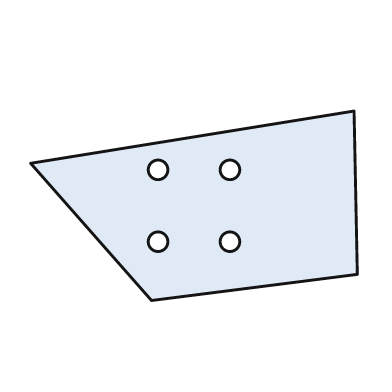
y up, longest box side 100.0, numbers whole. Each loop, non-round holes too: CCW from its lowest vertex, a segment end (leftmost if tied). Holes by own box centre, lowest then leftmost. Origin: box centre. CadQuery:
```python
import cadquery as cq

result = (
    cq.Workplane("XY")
    .moveTo(-13.0, -29.0)
    .lineTo(50.0, -21.0)
    .lineTo(49.0, 29.0)
    .lineTo(-50.0, 13.0)
    .close()
    .moveTo(-11.0, -11.0)
    .circle(3.0)
    .moveTo(11.0, -11.0)
    .circle(3.0)
    .moveTo(-11.0, 11.0)
    .circle(3.0)
    .moveTo(11.0, 11.0)
    .circle(3.0)
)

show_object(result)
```